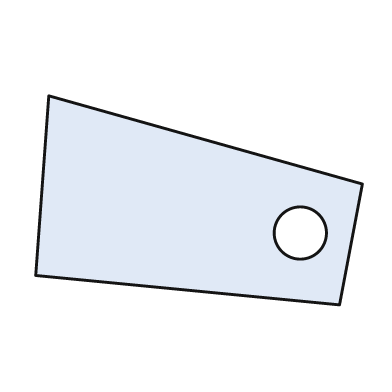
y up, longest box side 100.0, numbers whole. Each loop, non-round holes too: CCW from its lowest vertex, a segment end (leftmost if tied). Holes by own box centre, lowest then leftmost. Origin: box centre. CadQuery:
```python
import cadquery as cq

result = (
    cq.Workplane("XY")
    .moveTo(43.0, -32.0)
    .lineTo(50.0, 5.0)
    .lineTo(-46.0, 32.0)
    .lineTo(-50.0, -23.0)
    .close()
    .moveTo(31.0, -10.0)
    .circle(8.0)
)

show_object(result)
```